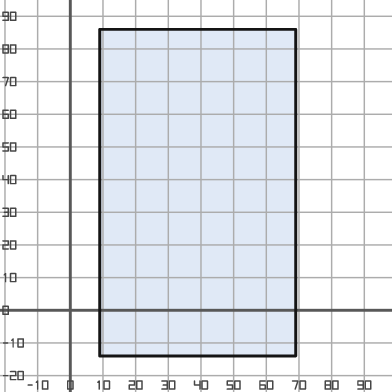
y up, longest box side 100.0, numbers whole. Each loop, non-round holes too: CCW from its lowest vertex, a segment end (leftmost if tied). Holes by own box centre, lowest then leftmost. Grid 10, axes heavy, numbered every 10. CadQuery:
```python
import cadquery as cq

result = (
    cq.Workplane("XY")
    .moveTo(9.0, -14.0)
    .lineTo(69.0, -14.0)
    .lineTo(69.0, 86.0)
    .lineTo(9.0, 86.0)
    .close()
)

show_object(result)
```